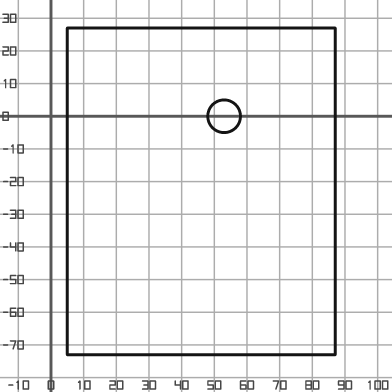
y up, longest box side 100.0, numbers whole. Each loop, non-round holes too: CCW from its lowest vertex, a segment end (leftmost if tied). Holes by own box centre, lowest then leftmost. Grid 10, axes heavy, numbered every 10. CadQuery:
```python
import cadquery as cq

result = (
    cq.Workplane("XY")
    .moveTo(5.0, -73.0)
    .lineTo(87.0, -73.0)
    .lineTo(87.0, 27.0)
    .lineTo(5.0, 27.0)
    .close()
    .moveTo(53.0, 0.0)
    .circle(5.0)
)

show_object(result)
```